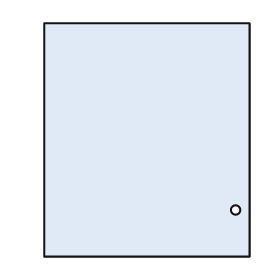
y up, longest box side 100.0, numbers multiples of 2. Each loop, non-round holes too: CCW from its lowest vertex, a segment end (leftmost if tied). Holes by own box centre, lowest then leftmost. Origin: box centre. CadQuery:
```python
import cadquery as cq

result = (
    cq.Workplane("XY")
    .moveTo(-44.0, -50.0)
    .lineTo(44.0, -50.0)
    .lineTo(44.0, 50.0)
    .lineTo(-44.0, 50.0)
    .close()
    .moveTo(38.0, -30.0)
    .circle(2.0)
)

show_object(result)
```